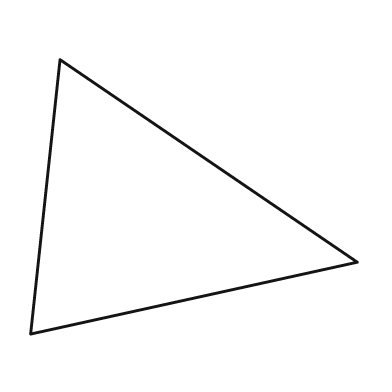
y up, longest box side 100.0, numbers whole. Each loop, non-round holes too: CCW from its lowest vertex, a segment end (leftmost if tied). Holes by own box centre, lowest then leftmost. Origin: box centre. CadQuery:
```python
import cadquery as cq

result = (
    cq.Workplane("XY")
    .moveTo(-50.0, -42.0)
    .lineTo(50.0, -20.0)
    .lineTo(-41.0, 42.0)
    .close()
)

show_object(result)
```